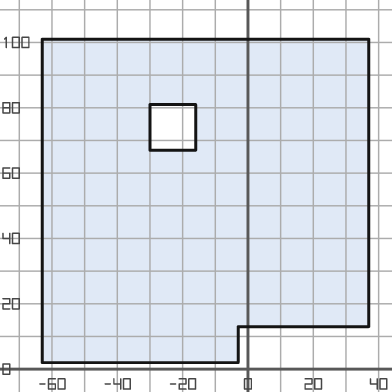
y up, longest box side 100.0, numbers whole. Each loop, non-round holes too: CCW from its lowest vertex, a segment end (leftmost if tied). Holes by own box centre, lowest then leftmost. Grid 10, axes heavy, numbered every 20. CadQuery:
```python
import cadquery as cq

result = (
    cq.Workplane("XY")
    .moveTo(-63.0, 2.0)
    .lineTo(-3.0, 2.0)
    .lineTo(-3.0, 13.0)
    .lineTo(37.0, 13.0)
    .lineTo(37.0, 101.0)
    .lineTo(-63.0, 101.0)
    .close()
    .moveTo(-30.0, 67.0)
    .lineTo(-16.0, 67.0)
    .lineTo(-16.0, 81.0)
    .lineTo(-30.0, 81.0)
    .close()
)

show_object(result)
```